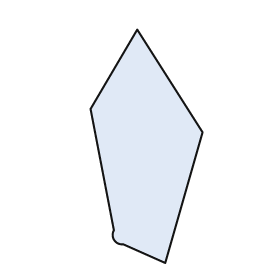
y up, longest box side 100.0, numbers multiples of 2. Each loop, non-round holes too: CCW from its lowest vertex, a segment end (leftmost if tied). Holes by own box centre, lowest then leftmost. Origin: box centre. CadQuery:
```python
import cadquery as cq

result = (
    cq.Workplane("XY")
    .moveTo(8.0, -50.0)
    .lineTo(24.0, 6.0)
    .lineTo(-4.0, 50.0)
    .lineTo(-24.0, 16.0)
    .lineTo(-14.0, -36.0)
    .threePointArc((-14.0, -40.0), (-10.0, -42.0))
    .close()
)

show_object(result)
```